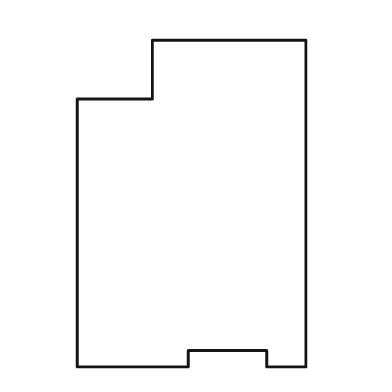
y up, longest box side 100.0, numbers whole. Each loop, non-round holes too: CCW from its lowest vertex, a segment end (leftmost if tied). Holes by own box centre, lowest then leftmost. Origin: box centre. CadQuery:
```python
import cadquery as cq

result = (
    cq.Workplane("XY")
    .moveTo(-35.0, -50.0)
    .lineTo(-1.0, -50.0)
    .lineTo(-1.0, -45.0)
    .lineTo(23.0, -45.0)
    .lineTo(23.0, -50.0)
    .lineTo(35.0, -50.0)
    .lineTo(35.0, 50.0)
    .lineTo(-12.0, 50.0)
    .lineTo(-12.0, 32.0)
    .lineTo(-35.0, 32.0)
    .close()
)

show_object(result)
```